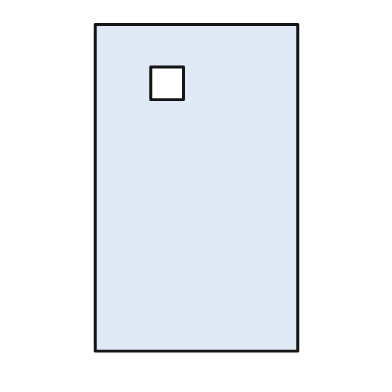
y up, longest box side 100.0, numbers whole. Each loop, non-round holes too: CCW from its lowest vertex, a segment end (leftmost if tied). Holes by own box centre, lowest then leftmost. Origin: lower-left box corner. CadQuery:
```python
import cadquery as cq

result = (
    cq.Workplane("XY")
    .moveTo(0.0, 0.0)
    .lineTo(62.0, 0.0)
    .lineTo(62.0, 100.0)
    .lineTo(0.0, 100.0)
    .close()
    .moveTo(17.0, 77.0)
    .lineTo(27.0, 77.0)
    .lineTo(27.0, 87.0)
    .lineTo(17.0, 87.0)
    .close()
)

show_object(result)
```